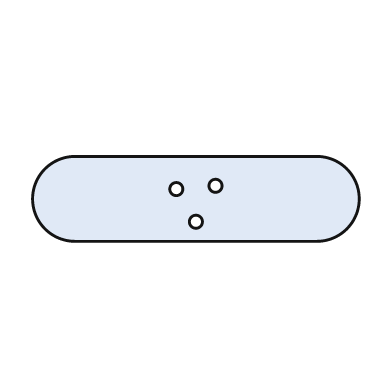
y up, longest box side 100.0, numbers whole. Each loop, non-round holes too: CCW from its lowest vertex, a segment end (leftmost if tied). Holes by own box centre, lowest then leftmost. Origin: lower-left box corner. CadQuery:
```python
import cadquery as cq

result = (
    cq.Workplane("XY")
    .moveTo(13.0, 0.0)
    .lineTo(87.0, 0.0)
    .threePointArc((100.0, 13.0), (87.0, 26.0))
    .lineTo(13.0, 26.0)
    .threePointArc((0.0, 13.0), (13.0, 0.0))
    .close()
    .moveTo(50.0, 6.0)
    .circle(2.0)
    .moveTo(44.0, 16.0)
    .circle(2.0)
    .moveTo(56.0, 17.0)
    .circle(2.0)
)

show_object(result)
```